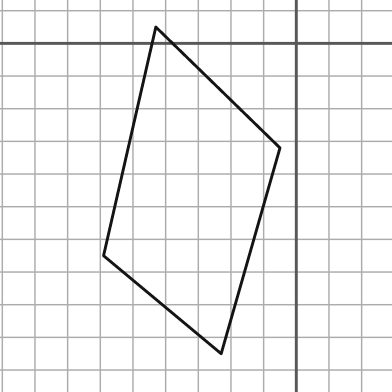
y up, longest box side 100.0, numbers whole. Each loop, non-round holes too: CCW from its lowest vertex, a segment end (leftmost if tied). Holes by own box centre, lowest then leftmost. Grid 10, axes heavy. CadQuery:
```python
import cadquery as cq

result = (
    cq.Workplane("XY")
    .moveTo(-23.0, -95.0)
    .lineTo(-5.0, -32.0)
    .lineTo(-43.0, 5.0)
    .lineTo(-59.0, -65.0)
    .close()
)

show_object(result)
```